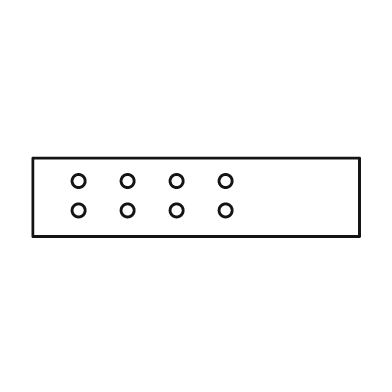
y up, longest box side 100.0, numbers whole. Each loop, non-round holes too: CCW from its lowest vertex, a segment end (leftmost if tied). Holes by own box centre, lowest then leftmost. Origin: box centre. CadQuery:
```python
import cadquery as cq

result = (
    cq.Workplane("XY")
    .moveTo(-50.0, -12.0)
    .lineTo(50.0, -12.0)
    .lineTo(50.0, 12.0)
    .lineTo(-50.0, 12.0)
    .close()
    .moveTo(-36.0, -4.0)
    .circle(2.0)
    .moveTo(-21.0, -4.0)
    .circle(2.0)
    .moveTo(-6.0, -4.0)
    .circle(2.0)
    .moveTo(9.0, -4.0)
    .circle(2.0)
    .moveTo(-36.0, 5.0)
    .circle(2.0)
    .moveTo(-21.0, 5.0)
    .circle(2.0)
    .moveTo(-6.0, 5.0)
    .circle(2.0)
    .moveTo(9.0, 5.0)
    .circle(2.0)
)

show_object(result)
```